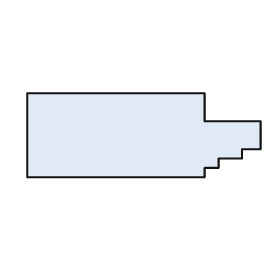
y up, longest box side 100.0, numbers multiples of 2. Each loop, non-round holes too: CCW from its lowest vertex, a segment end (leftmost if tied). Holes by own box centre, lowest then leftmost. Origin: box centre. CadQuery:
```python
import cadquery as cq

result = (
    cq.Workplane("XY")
    .moveTo(-50.0, -18.0)
    .lineTo(26.0, -18.0)
    .lineTo(26.0, -14.0)
    .lineTo(32.0, -14.0)
    .lineTo(32.0, -10.0)
    .lineTo(42.0, -10.0)
    .lineTo(42.0, -6.0)
    .lineTo(50.0, -6.0)
    .lineTo(50.0, 6.0)
    .lineTo(26.0, 6.0)
    .lineTo(26.0, 18.0)
    .lineTo(-50.0, 18.0)
    .close()
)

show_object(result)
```